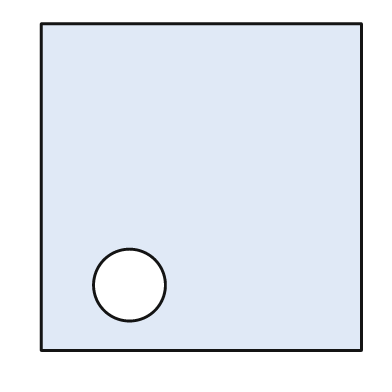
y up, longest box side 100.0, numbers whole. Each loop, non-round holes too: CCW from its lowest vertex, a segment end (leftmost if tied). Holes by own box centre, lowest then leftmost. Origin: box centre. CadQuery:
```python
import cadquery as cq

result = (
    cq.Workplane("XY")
    .moveTo(-49.0, -50.0)
    .lineTo(49.0, -50.0)
    .lineTo(49.0, 50.0)
    .lineTo(-49.0, 50.0)
    .close()
    .moveTo(-22.0, -30.0)
    .circle(11.0)
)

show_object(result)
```